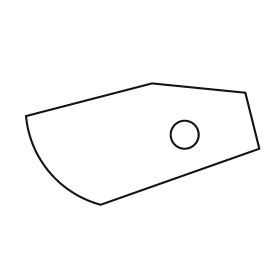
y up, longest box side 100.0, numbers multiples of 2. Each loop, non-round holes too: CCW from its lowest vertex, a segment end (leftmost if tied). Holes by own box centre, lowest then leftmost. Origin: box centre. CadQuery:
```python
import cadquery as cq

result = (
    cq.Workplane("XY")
    .moveTo(-18.0, -26.0)
    .lineTo(50.0, -2.0)
    .lineTo(44.0, 22.0)
    .lineTo(4.0, 26.0)
    .lineTo(-50.0, 12.0)
    .threePointArc((-40.0, -12.0), (-18.0, -26.0))
    .close()
    .moveTo(18.0, 4.0)
    .circle(6.0)
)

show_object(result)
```